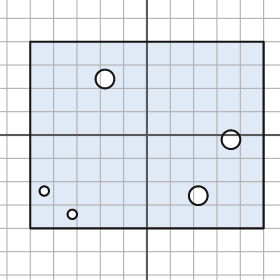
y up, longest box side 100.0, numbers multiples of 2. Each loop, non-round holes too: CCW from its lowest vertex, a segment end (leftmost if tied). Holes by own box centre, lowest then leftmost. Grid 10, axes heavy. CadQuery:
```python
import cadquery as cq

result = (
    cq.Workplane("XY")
    .moveTo(-50.0, -40.0)
    .lineTo(50.0, -40.0)
    .lineTo(50.0, 40.0)
    .lineTo(-50.0, 40.0)
    .close()
    .moveTo(-32.0, -34.0)
    .circle(2.0)
    .moveTo(22.0, -26.0)
    .circle(4.0)
    .moveTo(-44.0, -24.0)
    .circle(2.0)
    .moveTo(36.0, -2.0)
    .circle(4.0)
    .moveTo(-18.0, 24.0)
    .circle(4.0)
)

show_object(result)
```